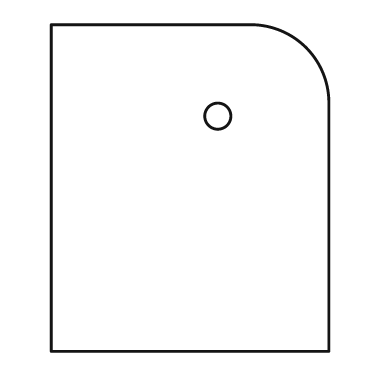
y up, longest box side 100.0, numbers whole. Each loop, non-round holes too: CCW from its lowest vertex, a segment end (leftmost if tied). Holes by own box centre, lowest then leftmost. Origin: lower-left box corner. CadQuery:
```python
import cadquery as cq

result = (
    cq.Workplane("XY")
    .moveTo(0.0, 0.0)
    .lineTo(85.0, 0.0)
    .lineTo(85.0, 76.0)
    .threePointArc((78.0, 93.0), (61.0, 100.0))
    .lineTo(0.0, 100.0)
    .close()
    .moveTo(51.0, 72.0)
    .circle(4.0)
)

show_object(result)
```